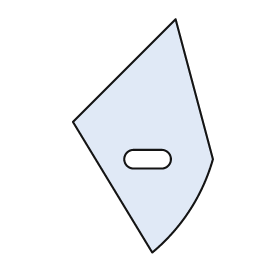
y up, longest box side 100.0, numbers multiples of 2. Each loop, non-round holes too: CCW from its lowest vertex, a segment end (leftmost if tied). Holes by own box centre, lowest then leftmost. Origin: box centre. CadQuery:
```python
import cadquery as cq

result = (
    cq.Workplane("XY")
    .moveTo(4.0, -50.0)
    .threePointArc((20.0, -32.0), (30.0, -10.0))
    .lineTo(14.0, 50.0)
    .lineTo(-30.0, 6.0)
    .close()
    .moveTo(-4.0, -14.0)
    .lineTo(8.0, -14.0)
    .threePointArc((12.0, -10.0), (8.0, -6.0))
    .lineTo(-4.0, -6.0)
    .threePointArc((-8.0, -10.0), (-4.0, -14.0))
    .close()
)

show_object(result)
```